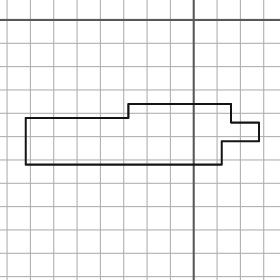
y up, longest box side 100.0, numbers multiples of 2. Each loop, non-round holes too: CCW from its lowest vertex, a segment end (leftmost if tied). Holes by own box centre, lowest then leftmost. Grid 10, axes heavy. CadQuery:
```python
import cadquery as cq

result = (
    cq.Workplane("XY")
    .moveTo(-72.0, -62.0)
    .lineTo(12.0, -62.0)
    .lineTo(12.0, -52.0)
    .lineTo(28.0, -52.0)
    .lineTo(28.0, -44.0)
    .lineTo(16.0, -44.0)
    .lineTo(16.0, -36.0)
    .lineTo(-28.0, -36.0)
    .lineTo(-28.0, -42.0)
    .lineTo(-72.0, -42.0)
    .close()
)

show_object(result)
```